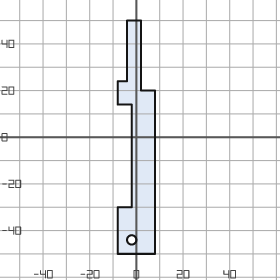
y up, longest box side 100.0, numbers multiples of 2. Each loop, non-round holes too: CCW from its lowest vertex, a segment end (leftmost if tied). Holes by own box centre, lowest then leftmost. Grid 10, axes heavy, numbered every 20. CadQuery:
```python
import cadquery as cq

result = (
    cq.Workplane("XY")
    .moveTo(-8.0, -50.0)
    .lineTo(8.0, -50.0)
    .lineTo(8.0, 20.0)
    .lineTo(2.0, 20.0)
    .lineTo(2.0, 50.0)
    .lineTo(-4.0, 50.0)
    .lineTo(-4.0, 24.0)
    .lineTo(-8.0, 24.0)
    .lineTo(-8.0, 14.0)
    .lineTo(-2.0, 14.0)
    .lineTo(-2.0, -30.0)
    .lineTo(-8.0, -30.0)
    .close()
    .moveTo(-2.0, -44.0)
    .circle(2.0)
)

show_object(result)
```